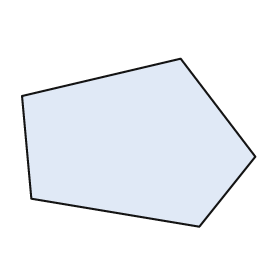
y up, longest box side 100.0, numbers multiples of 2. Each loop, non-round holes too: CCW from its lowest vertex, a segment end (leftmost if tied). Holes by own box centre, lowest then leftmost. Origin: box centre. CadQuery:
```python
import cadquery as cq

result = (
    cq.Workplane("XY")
    .moveTo(26.0, -36.0)
    .lineTo(50.0, -6.0)
    .lineTo(18.0, 36.0)
    .lineTo(-50.0, 20.0)
    .lineTo(-46.0, -24.0)
    .close()
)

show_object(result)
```